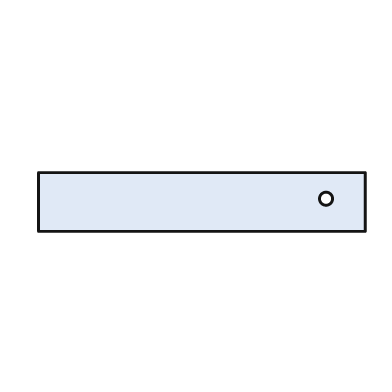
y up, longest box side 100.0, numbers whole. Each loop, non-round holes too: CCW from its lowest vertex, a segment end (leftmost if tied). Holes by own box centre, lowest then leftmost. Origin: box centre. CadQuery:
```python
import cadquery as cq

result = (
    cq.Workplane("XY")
    .moveTo(-50.0, -9.0)
    .lineTo(50.0, -9.0)
    .lineTo(50.0, 9.0)
    .lineTo(-50.0, 9.0)
    .close()
    .moveTo(38.0, 1.0)
    .circle(2.0)
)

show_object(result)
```